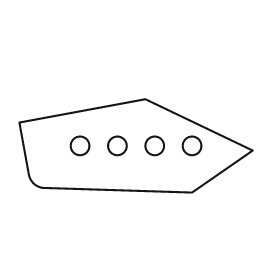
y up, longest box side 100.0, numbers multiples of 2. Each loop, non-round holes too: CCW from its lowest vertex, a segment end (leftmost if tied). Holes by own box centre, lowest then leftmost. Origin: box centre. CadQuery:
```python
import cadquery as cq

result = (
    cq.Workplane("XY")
    .moveTo(24.0, -20.0)
    .lineTo(50.0, -2.0)
    .lineTo(4.0, 20.0)
    .lineTo(-50.0, 10.0)
    .lineTo(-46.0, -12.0)
    .threePointArc((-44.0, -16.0), (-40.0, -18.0))
    .close()
    .moveTo(-24.0, 0.0)
    .circle(4.0)
    .moveTo(-8.0, 0.0)
    .circle(4.0)
    .moveTo(8.0, 0.0)
    .circle(4.0)
    .moveTo(24.0, 0.0)
    .circle(4.0)
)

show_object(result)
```